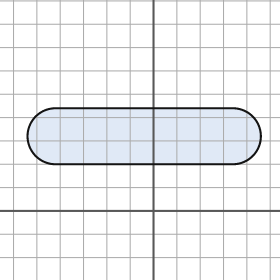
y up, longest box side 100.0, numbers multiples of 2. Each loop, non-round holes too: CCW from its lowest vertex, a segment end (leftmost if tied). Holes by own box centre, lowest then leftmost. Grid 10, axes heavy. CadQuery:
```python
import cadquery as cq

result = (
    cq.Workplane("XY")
    .moveTo(-42.0, 20.0)
    .lineTo(34.0, 20.0)
    .threePointArc((46.0, 32.0), (34.0, 44.0))
    .lineTo(-42.0, 44.0)
    .threePointArc((-54.0, 32.0), (-42.0, 20.0))
    .close()
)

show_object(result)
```